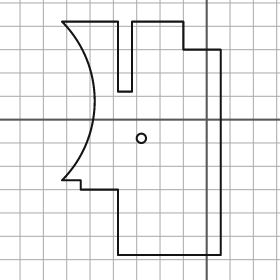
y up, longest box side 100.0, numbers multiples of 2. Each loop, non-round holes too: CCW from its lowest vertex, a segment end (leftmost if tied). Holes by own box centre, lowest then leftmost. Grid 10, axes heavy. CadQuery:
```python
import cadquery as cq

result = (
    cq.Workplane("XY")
    .moveTo(-38.0, -58.0)
    .lineTo(6.0, -58.0)
    .lineTo(6.0, 30.0)
    .lineTo(-10.0, 30.0)
    .lineTo(-10.0, 42.0)
    .lineTo(-32.0, 42.0)
    .lineTo(-32.0, 12.0)
    .lineTo(-38.0, 12.0)
    .lineTo(-38.0, 42.0)
    .lineTo(-62.0, 42.0)
    .threePointArc((-48.0, 8.0), (-62.0, -26.0))
    .lineTo(-54.0, -26.0)
    .lineTo(-54.0, -30.0)
    .lineTo(-38.0, -30.0)
    .close()
    .moveTo(-28.0, -8.0)
    .circle(2.0)
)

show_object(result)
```